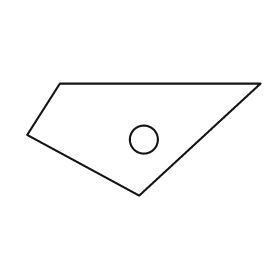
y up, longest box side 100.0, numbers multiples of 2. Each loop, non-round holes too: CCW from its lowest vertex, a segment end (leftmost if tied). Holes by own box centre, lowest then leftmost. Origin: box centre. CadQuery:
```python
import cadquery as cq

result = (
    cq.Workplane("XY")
    .moveTo(-2.0, -24.0)
    .lineTo(50.0, 24.0)
    .lineTo(-36.0, 24.0)
    .lineTo(-50.0, 2.0)
    .close()
    .moveTo(0.0, 0.0)
    .circle(6.0)
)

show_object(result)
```